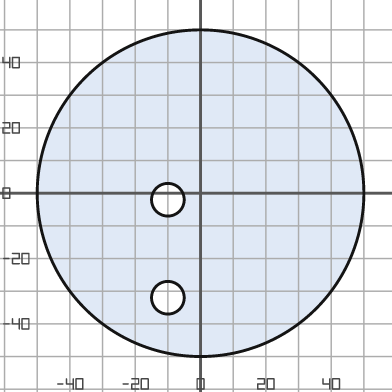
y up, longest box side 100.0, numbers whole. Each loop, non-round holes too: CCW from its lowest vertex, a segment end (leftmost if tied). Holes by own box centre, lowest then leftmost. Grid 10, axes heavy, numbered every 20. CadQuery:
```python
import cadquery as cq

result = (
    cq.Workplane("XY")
    .moveTo(0.0, 0.0)
    .circle(50.0)
    .moveTo(-10.0, -32.0)
    .circle(5.0)
    .moveTo(-10.0, -2.0)
    .circle(5.0)
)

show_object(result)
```